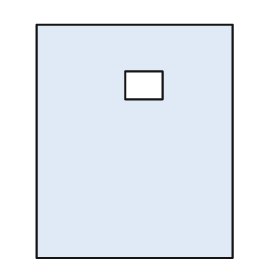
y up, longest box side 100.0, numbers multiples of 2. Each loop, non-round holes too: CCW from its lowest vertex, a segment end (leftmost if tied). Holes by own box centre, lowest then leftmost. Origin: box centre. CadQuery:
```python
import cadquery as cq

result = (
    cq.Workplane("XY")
    .moveTo(-42.0, -50.0)
    .lineTo(42.0, -50.0)
    .lineTo(42.0, 50.0)
    .lineTo(-42.0, 50.0)
    .close()
    .moveTo(-4.0, 18.0)
    .lineTo(12.0, 18.0)
    .lineTo(12.0, 30.0)
    .lineTo(-4.0, 30.0)
    .close()
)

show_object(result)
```